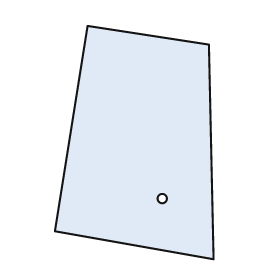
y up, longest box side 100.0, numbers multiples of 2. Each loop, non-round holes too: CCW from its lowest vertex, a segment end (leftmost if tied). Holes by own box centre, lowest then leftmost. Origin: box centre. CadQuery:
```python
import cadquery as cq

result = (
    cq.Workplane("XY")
    .moveTo(34.0, -50.0)
    .lineTo(32.0, 42.0)
    .lineTo(-20.0, 50.0)
    .lineTo(-34.0, -38.0)
    .close()
    .moveTo(12.0, -24.0)
    .circle(2.0)
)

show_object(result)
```